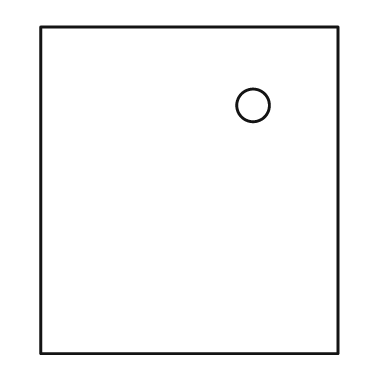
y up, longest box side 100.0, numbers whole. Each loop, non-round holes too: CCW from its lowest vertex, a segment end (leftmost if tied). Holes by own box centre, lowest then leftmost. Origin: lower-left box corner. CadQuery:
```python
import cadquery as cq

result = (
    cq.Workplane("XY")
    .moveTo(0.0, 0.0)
    .lineTo(91.0, 0.0)
    .lineTo(91.0, 100.0)
    .lineTo(0.0, 100.0)
    .close()
    .moveTo(65.0, 76.0)
    .circle(5.0)
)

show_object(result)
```